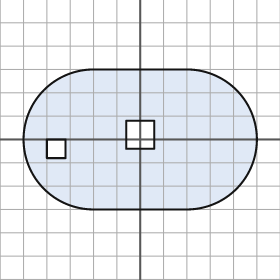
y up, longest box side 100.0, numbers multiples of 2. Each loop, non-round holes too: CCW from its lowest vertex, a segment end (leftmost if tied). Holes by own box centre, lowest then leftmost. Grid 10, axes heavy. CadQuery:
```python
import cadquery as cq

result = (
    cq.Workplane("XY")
    .moveTo(-20.0, -30.0)
    .lineTo(20.0, -30.0)
    .threePointArc((50.0, 0.0), (20.0, 30.0))
    .lineTo(-20.0, 30.0)
    .threePointArc((-50.0, 0.0), (-20.0, -30.0))
    .close()
    .moveTo(-40.0, -8.0)
    .lineTo(-32.0, -8.0)
    .lineTo(-32.0, 0.0)
    .lineTo(-40.0, 0.0)
    .close()
    .moveTo(-6.0, -4.0)
    .lineTo(6.0, -4.0)
    .lineTo(6.0, 8.0)
    .lineTo(-6.0, 8.0)
    .close()
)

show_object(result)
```